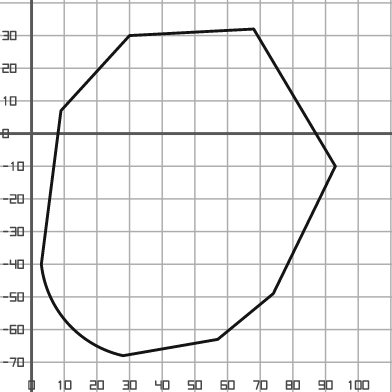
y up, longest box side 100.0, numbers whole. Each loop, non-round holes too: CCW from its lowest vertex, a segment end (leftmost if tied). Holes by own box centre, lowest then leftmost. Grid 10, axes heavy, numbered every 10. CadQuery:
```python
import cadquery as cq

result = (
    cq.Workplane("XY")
    .moveTo(28.0, -68.0)
    .lineTo(57.0, -63.0)
    .lineTo(74.0, -49.0)
    .lineTo(93.0, -10.0)
    .lineTo(68.0, 32.0)
    .lineTo(30.0, 30.0)
    .lineTo(9.0, 7.0)
    .lineTo(3.0, -40.0)
    .threePointArc((11.0, -58.0), (28.0, -68.0))
    .close()
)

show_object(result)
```